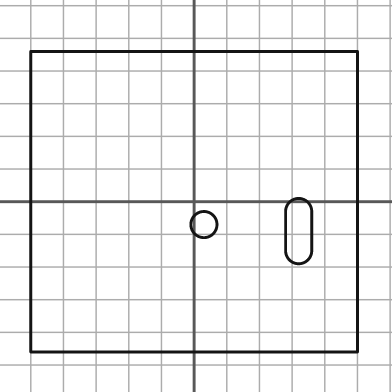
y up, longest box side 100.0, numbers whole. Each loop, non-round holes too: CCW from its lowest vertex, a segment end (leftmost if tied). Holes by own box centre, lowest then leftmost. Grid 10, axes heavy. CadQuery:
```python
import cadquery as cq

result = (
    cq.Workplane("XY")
    .moveTo(-50.0, -46.0)
    .lineTo(50.0, -46.0)
    .lineTo(50.0, 46.0)
    .lineTo(-50.0, 46.0)
    .close()
    .moveTo(28.0, -15.0)
    .threePointArc((32.0, -19.0), (36.0, -15.0))
    .lineTo(36.0, -3.0)
    .threePointArc((32.0, 1.0), (28.0, -3.0))
    .close()
    .moveTo(3.0, -7.0)
    .circle(4.0)
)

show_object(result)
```